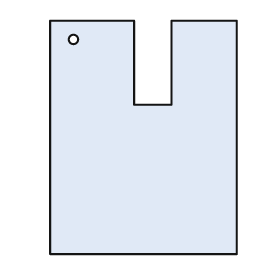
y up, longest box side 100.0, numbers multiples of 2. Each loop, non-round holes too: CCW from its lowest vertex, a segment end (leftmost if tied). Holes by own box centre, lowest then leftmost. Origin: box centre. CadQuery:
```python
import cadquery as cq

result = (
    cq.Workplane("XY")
    .moveTo(-40.0, -50.0)
    .lineTo(40.0, -50.0)
    .lineTo(40.0, 50.0)
    .lineTo(12.0, 50.0)
    .lineTo(12.0, 14.0)
    .lineTo(-4.0, 14.0)
    .lineTo(-4.0, 50.0)
    .lineTo(-40.0, 50.0)
    .close()
    .moveTo(-30.0, 42.0)
    .circle(2.0)
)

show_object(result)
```